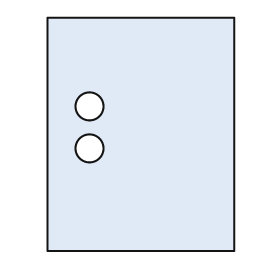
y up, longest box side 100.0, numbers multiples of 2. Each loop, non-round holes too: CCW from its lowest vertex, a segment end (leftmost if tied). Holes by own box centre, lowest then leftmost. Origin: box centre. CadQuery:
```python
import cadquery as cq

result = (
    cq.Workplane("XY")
    .moveTo(-40.0, -50.0)
    .lineTo(40.0, -50.0)
    .lineTo(40.0, 50.0)
    .lineTo(-40.0, 50.0)
    .close()
    .moveTo(-22.0, -6.0)
    .circle(6.0)
    .moveTo(-22.0, 12.0)
    .circle(6.0)
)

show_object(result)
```